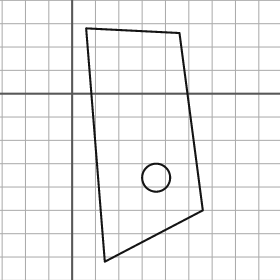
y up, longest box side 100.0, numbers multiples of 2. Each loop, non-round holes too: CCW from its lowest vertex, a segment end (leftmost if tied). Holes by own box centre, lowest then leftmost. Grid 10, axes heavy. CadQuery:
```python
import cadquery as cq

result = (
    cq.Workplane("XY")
    .moveTo(14.0, -72.0)
    .lineTo(56.0, -50.0)
    .lineTo(46.0, 26.0)
    .lineTo(6.0, 28.0)
    .close()
    .moveTo(36.0, -36.0)
    .circle(6.0)
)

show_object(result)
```